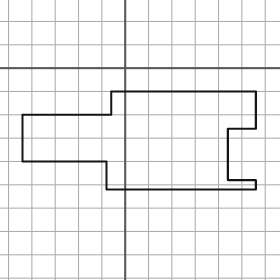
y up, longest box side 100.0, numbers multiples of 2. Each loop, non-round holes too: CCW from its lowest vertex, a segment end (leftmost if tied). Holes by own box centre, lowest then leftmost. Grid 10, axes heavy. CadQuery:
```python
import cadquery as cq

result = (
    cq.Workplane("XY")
    .moveTo(-8.0, -52.0)
    .lineTo(56.0, -52.0)
    .lineTo(56.0, -48.0)
    .lineTo(44.0, -48.0)
    .lineTo(44.0, -26.0)
    .lineTo(56.0, -26.0)
    .lineTo(56.0, -10.0)
    .lineTo(-6.0, -10.0)
    .lineTo(-6.0, -20.0)
    .lineTo(-44.0, -20.0)
    .lineTo(-44.0, -40.0)
    .lineTo(-8.0, -40.0)
    .close()
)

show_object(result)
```